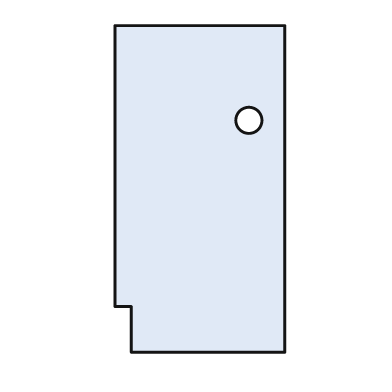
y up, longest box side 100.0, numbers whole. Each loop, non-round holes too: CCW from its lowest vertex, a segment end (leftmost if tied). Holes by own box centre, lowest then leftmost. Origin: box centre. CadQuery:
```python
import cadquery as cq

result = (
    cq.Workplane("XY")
    .moveTo(-21.0, -50.0)
    .lineTo(26.0, -50.0)
    .lineTo(26.0, 50.0)
    .lineTo(-26.0, 50.0)
    .lineTo(-26.0, -36.0)
    .lineTo(-21.0, -36.0)
    .close()
    .moveTo(15.0, 21.0)
    .circle(4.0)
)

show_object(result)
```